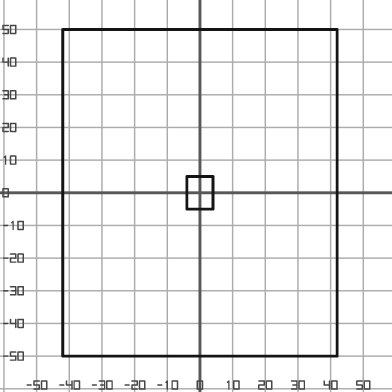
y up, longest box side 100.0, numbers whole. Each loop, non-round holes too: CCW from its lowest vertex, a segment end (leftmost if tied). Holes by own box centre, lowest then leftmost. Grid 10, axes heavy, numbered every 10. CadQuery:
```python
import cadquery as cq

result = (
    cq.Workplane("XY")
    .moveTo(-42.0, -50.0)
    .lineTo(42.0, -50.0)
    .lineTo(42.0, 50.0)
    .lineTo(-42.0, 50.0)
    .close()
    .moveTo(-4.0, -5.0)
    .lineTo(4.0, -5.0)
    .lineTo(4.0, 5.0)
    .lineTo(-4.0, 5.0)
    .close()
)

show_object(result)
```